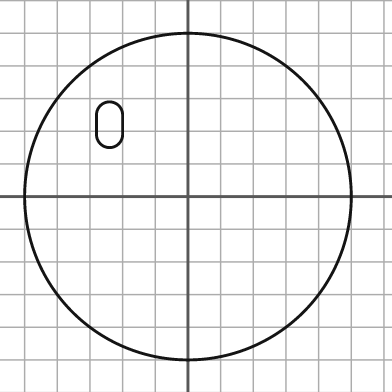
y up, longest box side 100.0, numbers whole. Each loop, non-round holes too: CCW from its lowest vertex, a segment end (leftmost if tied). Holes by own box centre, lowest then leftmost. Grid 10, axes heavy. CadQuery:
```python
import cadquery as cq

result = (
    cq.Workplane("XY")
    .moveTo(0.0, 0.0)
    .circle(50.0)
    .moveTo(-28.0, 19.0)
    .threePointArc((-24.0, 15.0), (-20.0, 19.0))
    .lineTo(-20.0, 25.0)
    .threePointArc((-24.0, 29.0), (-28.0, 25.0))
    .close()
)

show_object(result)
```